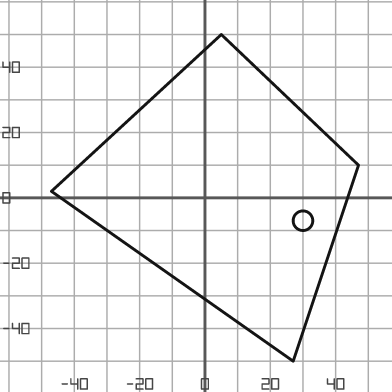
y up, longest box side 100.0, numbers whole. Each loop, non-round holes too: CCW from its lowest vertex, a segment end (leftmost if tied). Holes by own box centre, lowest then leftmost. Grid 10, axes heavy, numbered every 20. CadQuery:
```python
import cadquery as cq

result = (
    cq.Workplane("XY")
    .moveTo(27.0, -50.0)
    .lineTo(47.0, 10.0)
    .lineTo(5.0, 50.0)
    .lineTo(-47.0, 2.0)
    .close()
    .moveTo(30.0, -7.0)
    .circle(3.0)
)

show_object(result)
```